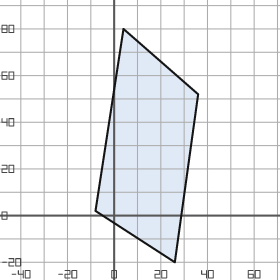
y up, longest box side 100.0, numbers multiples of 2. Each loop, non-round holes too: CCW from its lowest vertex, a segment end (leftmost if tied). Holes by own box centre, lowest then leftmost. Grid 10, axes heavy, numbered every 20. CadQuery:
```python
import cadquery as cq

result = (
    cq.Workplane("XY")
    .moveTo(26.0, -20.0)
    .lineTo(36.0, 52.0)
    .lineTo(4.0, 80.0)
    .lineTo(-8.0, 2.0)
    .close()
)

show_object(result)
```